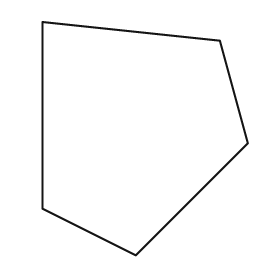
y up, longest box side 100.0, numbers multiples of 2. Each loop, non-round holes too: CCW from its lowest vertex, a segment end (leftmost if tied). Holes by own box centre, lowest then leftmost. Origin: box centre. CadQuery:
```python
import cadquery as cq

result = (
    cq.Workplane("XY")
    .moveTo(-4.0, -50.0)
    .lineTo(44.0, -2.0)
    .lineTo(32.0, 42.0)
    .lineTo(-44.0, 50.0)
    .lineTo(-44.0, -30.0)
    .close()
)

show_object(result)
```